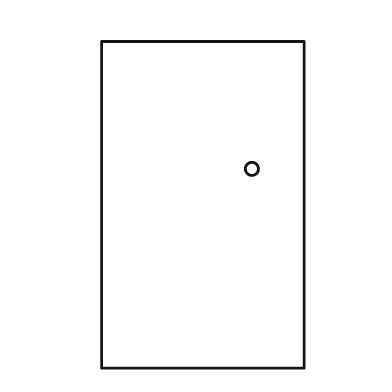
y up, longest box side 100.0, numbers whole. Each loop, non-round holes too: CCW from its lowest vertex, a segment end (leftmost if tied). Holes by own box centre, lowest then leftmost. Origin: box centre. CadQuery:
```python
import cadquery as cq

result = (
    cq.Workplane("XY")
    .moveTo(-31.0, -50.0)
    .lineTo(31.0, -50.0)
    .lineTo(31.0, 50.0)
    .lineTo(-31.0, 50.0)
    .close()
    .moveTo(15.0, 11.0)
    .circle(2.0)
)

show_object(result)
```